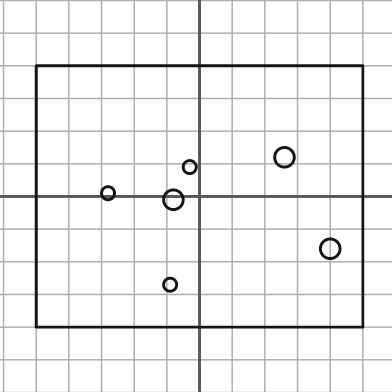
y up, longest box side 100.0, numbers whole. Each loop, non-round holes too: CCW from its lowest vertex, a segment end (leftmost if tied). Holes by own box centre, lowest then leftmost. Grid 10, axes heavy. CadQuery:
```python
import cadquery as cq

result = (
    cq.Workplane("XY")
    .moveTo(-50.0, -40.0)
    .lineTo(50.0, -40.0)
    .lineTo(50.0, 40.0)
    .lineTo(-50.0, 40.0)
    .close()
    .moveTo(-9.0, -27.0)
    .circle(2.0)
    .moveTo(40.0, -16.0)
    .circle(3.0)
    .moveTo(-8.0, -1.0)
    .circle(3.0)
    .moveTo(-28.0, 1.0)
    .circle(2.0)
    .moveTo(-3.0, 9.0)
    .circle(2.0)
    .moveTo(26.0, 12.0)
    .circle(3.0)
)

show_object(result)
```